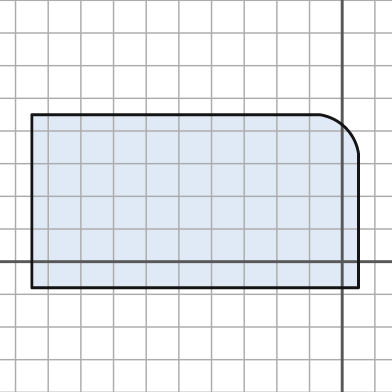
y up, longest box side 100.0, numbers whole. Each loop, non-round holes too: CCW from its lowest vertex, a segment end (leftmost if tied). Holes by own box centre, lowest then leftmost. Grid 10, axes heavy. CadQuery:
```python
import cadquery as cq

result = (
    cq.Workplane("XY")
    .moveTo(-95.0, -8.0)
    .lineTo(5.0, -8.0)
    .lineTo(5.0, 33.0)
    .threePointArc((1.0, 41.0), (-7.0, 45.0))
    .lineTo(-95.0, 45.0)
    .close()
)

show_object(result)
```